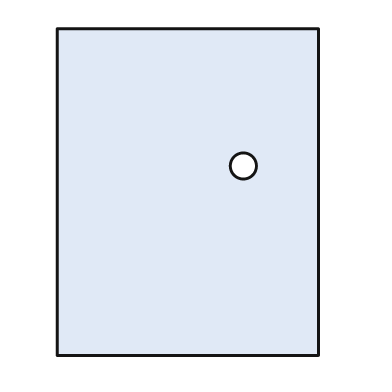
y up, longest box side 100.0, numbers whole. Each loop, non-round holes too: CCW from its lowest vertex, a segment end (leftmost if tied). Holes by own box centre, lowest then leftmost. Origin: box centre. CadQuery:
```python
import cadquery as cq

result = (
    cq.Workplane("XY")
    .moveTo(-40.0, -50.0)
    .lineTo(40.0, -50.0)
    .lineTo(40.0, 50.0)
    .lineTo(-40.0, 50.0)
    .close()
    .moveTo(17.0, 8.0)
    .circle(4.0)
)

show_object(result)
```